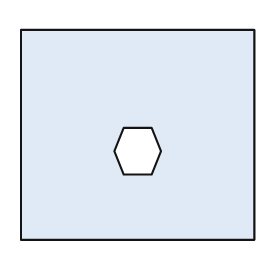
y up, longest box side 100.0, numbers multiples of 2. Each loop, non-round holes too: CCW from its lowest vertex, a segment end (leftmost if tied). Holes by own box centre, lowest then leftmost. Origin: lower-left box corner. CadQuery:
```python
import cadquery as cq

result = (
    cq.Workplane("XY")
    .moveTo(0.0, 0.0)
    .lineTo(100.0, 0.0)
    .lineTo(100.0, 90.0)
    .lineTo(0.0, 90.0)
    .close()
    .moveTo(44.0, 28.0)
    .lineTo(56.0, 28.0)
    .lineTo(60.0, 38.0)
    .lineTo(56.0, 48.0)
    .lineTo(44.0, 48.0)
    .lineTo(40.0, 38.0)
    .close()
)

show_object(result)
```